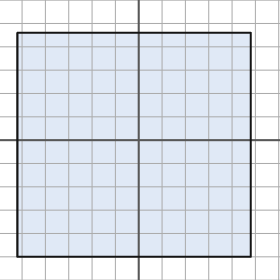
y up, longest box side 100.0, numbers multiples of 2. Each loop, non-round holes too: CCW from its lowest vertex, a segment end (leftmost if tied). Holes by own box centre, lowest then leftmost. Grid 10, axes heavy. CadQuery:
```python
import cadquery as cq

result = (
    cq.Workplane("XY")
    .moveTo(-52.0, -50.0)
    .lineTo(48.0, -50.0)
    .lineTo(48.0, 46.0)
    .lineTo(-52.0, 46.0)
    .close()
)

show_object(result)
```